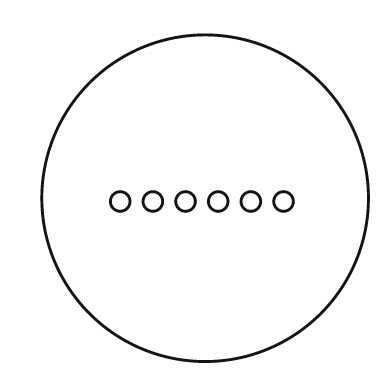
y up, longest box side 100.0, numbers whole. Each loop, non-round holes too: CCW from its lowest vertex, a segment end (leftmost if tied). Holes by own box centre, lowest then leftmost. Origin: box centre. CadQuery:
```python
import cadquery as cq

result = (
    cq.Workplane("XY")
    .moveTo(0.0, 0.0)
    .circle(50.0)
    .moveTo(-26.0, -1.0)
    .circle(3.0)
    .moveTo(-16.0, -1.0)
    .circle(3.0)
    .moveTo(-6.0, -1.0)
    .circle(3.0)
    .moveTo(4.0, -1.0)
    .circle(3.0)
    .moveTo(14.0, -1.0)
    .circle(3.0)
    .moveTo(24.0, -1.0)
    .circle(3.0)
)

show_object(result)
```